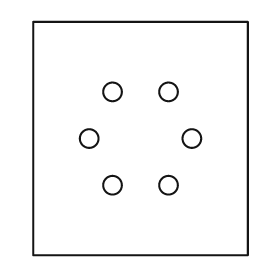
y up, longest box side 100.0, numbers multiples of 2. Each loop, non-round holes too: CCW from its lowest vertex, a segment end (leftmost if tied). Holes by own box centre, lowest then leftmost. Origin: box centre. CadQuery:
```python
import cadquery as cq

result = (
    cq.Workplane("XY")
    .moveTo(-46.0, -50.0)
    .lineTo(46.0, -50.0)
    .lineTo(46.0, 50.0)
    .lineTo(-46.0, 50.0)
    .close()
    .moveTo(-12.0, -20.0)
    .circle(4.0)
    .moveTo(12.0, -20.0)
    .circle(4.0)
    .moveTo(-22.0, 0.0)
    .circle(4.0)
    .moveTo(22.0, 0.0)
    .circle(4.0)
    .moveTo(-12.0, 20.0)
    .circle(4.0)
    .moveTo(12.0, 20.0)
    .circle(4.0)
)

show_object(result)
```